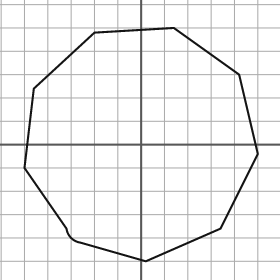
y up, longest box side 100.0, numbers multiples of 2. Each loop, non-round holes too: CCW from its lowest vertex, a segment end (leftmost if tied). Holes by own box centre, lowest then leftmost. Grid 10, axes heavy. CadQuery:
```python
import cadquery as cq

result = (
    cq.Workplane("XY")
    .moveTo(2.0, -50.0)
    .lineTo(34.0, -36.0)
    .lineTo(50.0, -4.0)
    .lineTo(42.0, 30.0)
    .lineTo(14.0, 50.0)
    .lineTo(-20.0, 48.0)
    .lineTo(-46.0, 24.0)
    .lineTo(-50.0, -10.0)
    .lineTo(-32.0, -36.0)
    .threePointArc((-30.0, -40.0), (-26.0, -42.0))
    .close()
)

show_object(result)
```